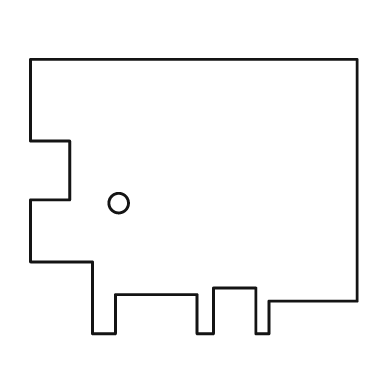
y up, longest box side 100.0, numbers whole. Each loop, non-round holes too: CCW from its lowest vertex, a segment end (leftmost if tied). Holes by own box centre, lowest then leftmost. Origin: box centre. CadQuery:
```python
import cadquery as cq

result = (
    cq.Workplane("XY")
    .moveTo(-31.0, -42.0)
    .lineTo(-24.0, -42.0)
    .lineTo(-24.0, -30.0)
    .lineTo(1.0, -30.0)
    .lineTo(1.0, -42.0)
    .lineTo(6.0, -42.0)
    .lineTo(6.0, -28.0)
    .lineTo(19.0, -28.0)
    .lineTo(19.0, -42.0)
    .lineTo(23.0, -42.0)
    .lineTo(23.0, -32.0)
    .lineTo(50.0, -32.0)
    .lineTo(50.0, 42.0)
    .lineTo(-50.0, 42.0)
    .lineTo(-50.0, 17.0)
    .lineTo(-38.0, 17.0)
    .lineTo(-38.0, -1.0)
    .lineTo(-50.0, -1.0)
    .lineTo(-50.0, -20.0)
    .lineTo(-31.0, -20.0)
    .close()
    .moveTo(-23.0, -2.0)
    .circle(3.0)
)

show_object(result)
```